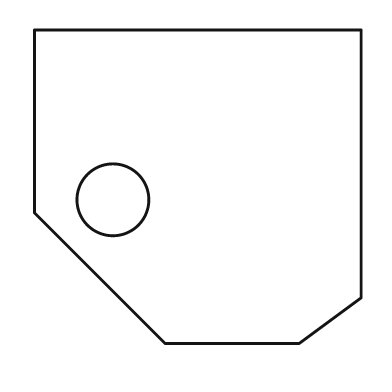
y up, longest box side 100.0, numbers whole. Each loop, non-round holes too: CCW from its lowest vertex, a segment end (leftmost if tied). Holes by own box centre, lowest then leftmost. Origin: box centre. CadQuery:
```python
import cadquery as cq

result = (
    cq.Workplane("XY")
    .moveTo(-10.0, -48.0)
    .lineTo(31.0, -48.0)
    .lineTo(50.0, -34.0)
    .lineTo(50.0, 48.0)
    .lineTo(-50.0, 48.0)
    .lineTo(-50.0, -8.0)
    .close()
    .moveTo(-26.0, -4.0)
    .circle(11.0)
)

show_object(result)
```